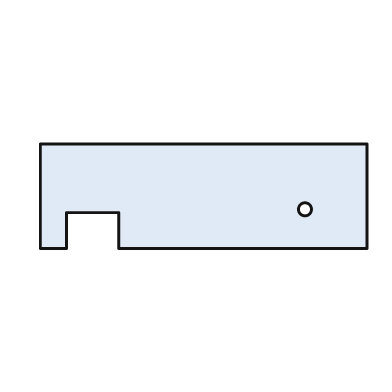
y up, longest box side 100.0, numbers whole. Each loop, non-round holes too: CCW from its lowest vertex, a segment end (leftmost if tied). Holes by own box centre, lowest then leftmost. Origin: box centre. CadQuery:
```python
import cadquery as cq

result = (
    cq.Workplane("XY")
    .moveTo(-50.0, -16.0)
    .lineTo(-42.0, -16.0)
    .lineTo(-42.0, -5.0)
    .lineTo(-26.0, -5.0)
    .lineTo(-26.0, -16.0)
    .lineTo(50.0, -16.0)
    .lineTo(50.0, 16.0)
    .lineTo(-50.0, 16.0)
    .close()
    .moveTo(31.0, -4.0)
    .circle(2.0)
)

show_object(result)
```